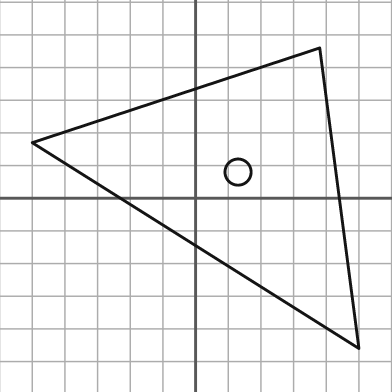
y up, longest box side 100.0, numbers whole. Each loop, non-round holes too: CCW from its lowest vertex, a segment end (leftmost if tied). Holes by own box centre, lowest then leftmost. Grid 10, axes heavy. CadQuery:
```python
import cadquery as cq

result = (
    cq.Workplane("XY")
    .moveTo(50.0, -46.0)
    .lineTo(38.0, 46.0)
    .lineTo(-50.0, 17.0)
    .close()
    .moveTo(13.0, 8.0)
    .circle(4.0)
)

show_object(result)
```